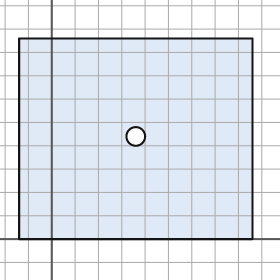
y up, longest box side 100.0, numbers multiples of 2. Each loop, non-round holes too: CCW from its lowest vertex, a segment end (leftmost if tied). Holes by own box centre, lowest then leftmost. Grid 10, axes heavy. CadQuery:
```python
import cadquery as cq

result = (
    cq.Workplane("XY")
    .moveTo(-14.0, 0.0)
    .lineTo(86.0, 0.0)
    .lineTo(86.0, 86.0)
    .lineTo(-14.0, 86.0)
    .close()
    .moveTo(36.0, 44.0)
    .circle(4.0)
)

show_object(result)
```